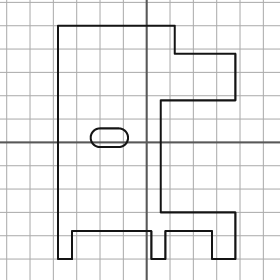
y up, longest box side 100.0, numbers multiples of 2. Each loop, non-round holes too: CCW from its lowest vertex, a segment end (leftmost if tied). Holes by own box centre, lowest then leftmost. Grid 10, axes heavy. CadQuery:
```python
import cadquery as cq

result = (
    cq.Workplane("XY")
    .moveTo(-38.0, -50.0)
    .lineTo(-32.0, -50.0)
    .lineTo(-32.0, -38.0)
    .lineTo(2.0, -38.0)
    .lineTo(2.0, -50.0)
    .lineTo(8.0, -50.0)
    .lineTo(8.0, -38.0)
    .lineTo(28.0, -38.0)
    .lineTo(28.0, -50.0)
    .lineTo(38.0, -50.0)
    .lineTo(38.0, -30.0)
    .lineTo(6.0, -30.0)
    .lineTo(6.0, 18.0)
    .lineTo(38.0, 18.0)
    .lineTo(38.0, 38.0)
    .lineTo(12.0, 38.0)
    .lineTo(12.0, 50.0)
    .lineTo(-38.0, 50.0)
    .close()
    .moveTo(-20.0, -2.0)
    .lineTo(-12.0, -2.0)
    .threePointArc((-8.0, 2.0), (-12.0, 6.0))
    .lineTo(-20.0, 6.0)
    .threePointArc((-24.0, 2.0), (-20.0, -2.0))
    .close()
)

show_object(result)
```